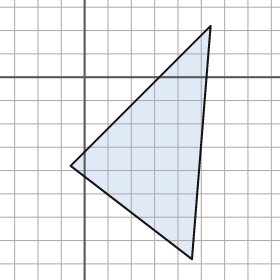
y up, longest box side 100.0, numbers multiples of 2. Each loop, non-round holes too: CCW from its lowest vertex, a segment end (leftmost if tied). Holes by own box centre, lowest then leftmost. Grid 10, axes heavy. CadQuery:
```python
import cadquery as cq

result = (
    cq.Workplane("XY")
    .moveTo(46.0, -78.0)
    .lineTo(54.0, 22.0)
    .lineTo(-6.0, -38.0)
    .close()
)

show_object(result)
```